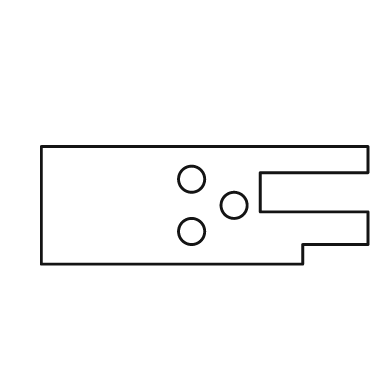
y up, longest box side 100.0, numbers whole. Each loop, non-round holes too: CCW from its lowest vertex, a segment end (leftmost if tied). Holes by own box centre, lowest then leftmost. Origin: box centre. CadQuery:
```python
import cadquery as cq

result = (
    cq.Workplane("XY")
    .moveTo(-50.0, -18.0)
    .lineTo(30.0, -18.0)
    .lineTo(30.0, -12.0)
    .lineTo(50.0, -12.0)
    .lineTo(50.0, -2.0)
    .lineTo(17.0, -2.0)
    .lineTo(17.0, 10.0)
    .lineTo(50.0, 10.0)
    .lineTo(50.0, 18.0)
    .lineTo(-50.0, 18.0)
    .close()
    .moveTo(-4.0, -8.0)
    .circle(4.0)
    .moveTo(9.0, 0.0)
    .circle(4.0)
    .moveTo(-4.0, 8.0)
    .circle(4.0)
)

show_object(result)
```